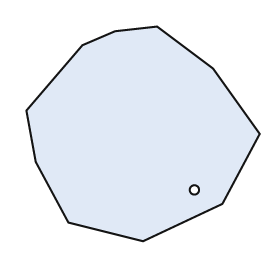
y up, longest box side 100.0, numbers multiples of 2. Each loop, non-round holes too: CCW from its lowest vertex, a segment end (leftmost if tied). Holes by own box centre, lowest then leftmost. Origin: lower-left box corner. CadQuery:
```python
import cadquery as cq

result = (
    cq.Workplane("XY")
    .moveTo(50.0, 0.0)
    .lineTo(84.0, 16.0)
    .lineTo(100.0, 46.0)
    .lineTo(80.0, 74.0)
    .lineTo(56.0, 92.0)
    .lineTo(38.0, 90.0)
    .lineTo(24.0, 84.0)
    .lineTo(0.0, 56.0)
    .lineTo(4.0, 34.0)
    .lineTo(18.0, 8.0)
    .close()
    .moveTo(72.0, 22.0)
    .circle(2.0)
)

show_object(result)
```